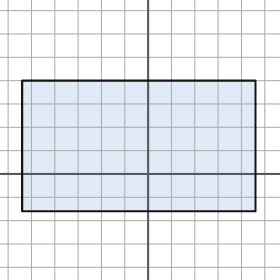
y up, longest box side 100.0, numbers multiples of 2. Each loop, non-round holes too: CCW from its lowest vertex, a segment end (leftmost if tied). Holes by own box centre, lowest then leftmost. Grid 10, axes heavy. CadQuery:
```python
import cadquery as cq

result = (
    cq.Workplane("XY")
    .moveTo(-54.0, -16.0)
    .lineTo(46.0, -16.0)
    .lineTo(46.0, 40.0)
    .lineTo(-54.0, 40.0)
    .close()
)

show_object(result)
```